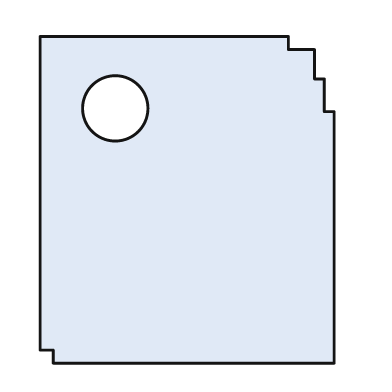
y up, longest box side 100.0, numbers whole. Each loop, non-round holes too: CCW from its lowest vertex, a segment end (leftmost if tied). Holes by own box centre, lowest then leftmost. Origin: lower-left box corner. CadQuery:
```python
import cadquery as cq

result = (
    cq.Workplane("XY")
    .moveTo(4.0, 0.0)
    .lineTo(90.0, 0.0)
    .lineTo(90.0, 77.0)
    .lineTo(87.0, 77.0)
    .lineTo(87.0, 87.0)
    .lineTo(84.0, 87.0)
    .lineTo(84.0, 96.0)
    .lineTo(76.0, 96.0)
    .lineTo(76.0, 100.0)
    .lineTo(0.0, 100.0)
    .lineTo(0.0, 4.0)
    .lineTo(4.0, 4.0)
    .close()
    .moveTo(23.0, 78.0)
    .circle(10.0)
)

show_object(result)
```